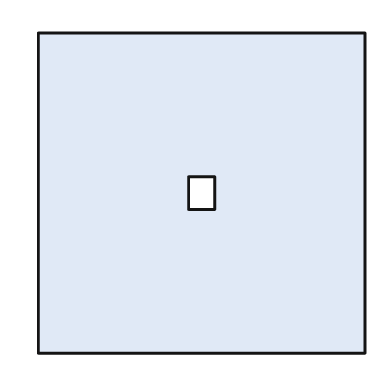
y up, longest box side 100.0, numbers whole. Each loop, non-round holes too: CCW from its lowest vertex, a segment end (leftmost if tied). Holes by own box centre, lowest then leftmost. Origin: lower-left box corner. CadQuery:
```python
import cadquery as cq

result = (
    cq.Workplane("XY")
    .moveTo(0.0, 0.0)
    .lineTo(100.0, 0.0)
    .lineTo(100.0, 98.0)
    .lineTo(0.0, 98.0)
    .close()
    .moveTo(46.0, 44.0)
    .lineTo(54.0, 44.0)
    .lineTo(54.0, 54.0)
    .lineTo(46.0, 54.0)
    .close()
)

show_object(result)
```